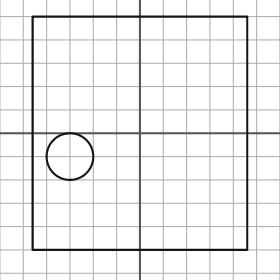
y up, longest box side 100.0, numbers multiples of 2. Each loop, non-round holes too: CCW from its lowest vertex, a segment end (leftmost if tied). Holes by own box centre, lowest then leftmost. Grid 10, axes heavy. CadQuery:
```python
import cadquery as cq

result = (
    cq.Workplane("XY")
    .moveTo(-46.0, -50.0)
    .lineTo(46.0, -50.0)
    .lineTo(46.0, 50.0)
    .lineTo(-46.0, 50.0)
    .close()
    .moveTo(-30.0, -10.0)
    .circle(10.0)
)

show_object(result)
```